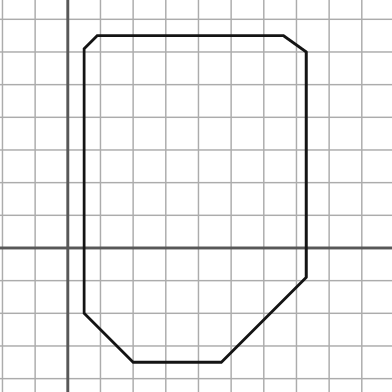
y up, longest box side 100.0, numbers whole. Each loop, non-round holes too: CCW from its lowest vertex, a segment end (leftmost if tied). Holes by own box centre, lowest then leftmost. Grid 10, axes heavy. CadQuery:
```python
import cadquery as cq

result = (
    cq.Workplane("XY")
    .moveTo(20.0, -35.0)
    .lineTo(47.0, -35.0)
    .lineTo(73.0, -9.0)
    .lineTo(73.0, 60.0)
    .lineTo(66.0, 65.0)
    .lineTo(9.0, 65.0)
    .lineTo(5.0, 61.0)
    .lineTo(5.0, -20.0)
    .close()
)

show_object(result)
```